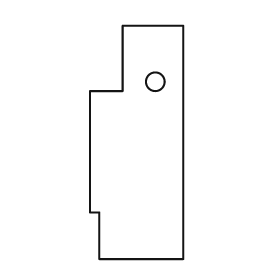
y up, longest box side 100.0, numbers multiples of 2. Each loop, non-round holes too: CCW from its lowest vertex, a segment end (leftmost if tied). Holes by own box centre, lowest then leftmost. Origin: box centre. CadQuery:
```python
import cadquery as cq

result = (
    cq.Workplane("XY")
    .moveTo(-16.0, -50.0)
    .lineTo(20.0, -50.0)
    .lineTo(20.0, 50.0)
    .lineTo(-6.0, 50.0)
    .lineTo(-6.0, 22.0)
    .lineTo(-20.0, 22.0)
    .lineTo(-20.0, -30.0)
    .lineTo(-16.0, -30.0)
    .close()
    .moveTo(8.0, 26.0)
    .circle(4.0)
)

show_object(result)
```